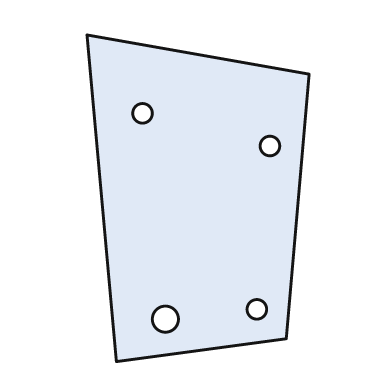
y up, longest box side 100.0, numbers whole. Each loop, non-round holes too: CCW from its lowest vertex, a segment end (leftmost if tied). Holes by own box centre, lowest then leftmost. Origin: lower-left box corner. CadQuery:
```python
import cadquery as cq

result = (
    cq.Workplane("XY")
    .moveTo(9.0, 0.0)
    .lineTo(61.0, 7.0)
    .lineTo(68.0, 88.0)
    .lineTo(0.0, 100.0)
    .close()
    .moveTo(24.0, 13.0)
    .circle(4.0)
    .moveTo(52.0, 16.0)
    .circle(3.0)
    .moveTo(56.0, 66.0)
    .circle(3.0)
    .moveTo(17.0, 76.0)
    .circle(3.0)
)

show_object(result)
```